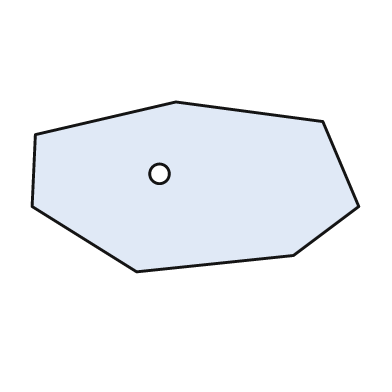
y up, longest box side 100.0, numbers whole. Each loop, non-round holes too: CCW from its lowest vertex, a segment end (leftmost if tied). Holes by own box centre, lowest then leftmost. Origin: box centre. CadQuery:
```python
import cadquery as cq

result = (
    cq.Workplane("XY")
    .moveTo(-18.0, -26.0)
    .lineTo(30.0, -21.0)
    .lineTo(50.0, -6.0)
    .lineTo(39.0, 20.0)
    .lineTo(-6.0, 26.0)
    .lineTo(-49.0, 16.0)
    .lineTo(-50.0, -6.0)
    .close()
    .moveTo(-11.0, 4.0)
    .circle(3.0)
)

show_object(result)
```